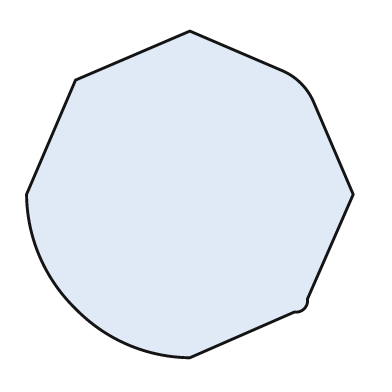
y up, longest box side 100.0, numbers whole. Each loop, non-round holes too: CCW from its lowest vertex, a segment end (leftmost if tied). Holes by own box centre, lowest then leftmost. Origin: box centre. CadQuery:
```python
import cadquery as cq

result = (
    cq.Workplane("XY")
    .moveTo(0.0, -50.0)
    .lineTo(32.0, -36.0)
    .threePointArc((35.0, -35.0), (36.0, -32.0))
    .lineTo(50.0, 0.0)
    .lineTo(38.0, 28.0)
    .threePointArc((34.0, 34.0), (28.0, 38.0))
    .lineTo(0.0, 50.0)
    .lineTo(-35.0, 35.0)
    .lineTo(-50.0, 0.0)
    .threePointArc((-46.0, -19.0), (-35.0, -35.0))
    .threePointArc((-19.0, -46.0), (0.0, -50.0))
    .close()
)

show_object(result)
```